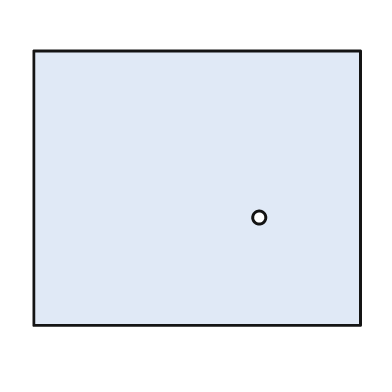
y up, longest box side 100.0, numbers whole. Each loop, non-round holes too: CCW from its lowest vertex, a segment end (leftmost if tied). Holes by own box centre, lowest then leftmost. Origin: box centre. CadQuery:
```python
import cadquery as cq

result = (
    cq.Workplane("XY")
    .moveTo(-50.0, -42.0)
    .lineTo(50.0, -42.0)
    .lineTo(50.0, 42.0)
    .lineTo(-50.0, 42.0)
    .close()
    .moveTo(19.0, -9.0)
    .circle(2.0)
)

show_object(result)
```